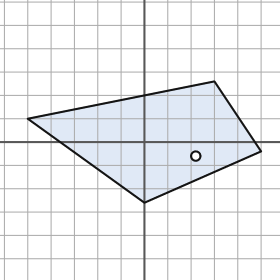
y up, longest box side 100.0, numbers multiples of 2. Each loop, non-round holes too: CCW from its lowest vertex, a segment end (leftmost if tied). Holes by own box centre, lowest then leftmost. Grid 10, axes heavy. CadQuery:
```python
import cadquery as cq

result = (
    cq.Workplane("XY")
    .moveTo(0.0, -26.0)
    .lineTo(50.0, -4.0)
    .lineTo(30.0, 26.0)
    .lineTo(-50.0, 10.0)
    .close()
    .moveTo(22.0, -6.0)
    .circle(2.0)
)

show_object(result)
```